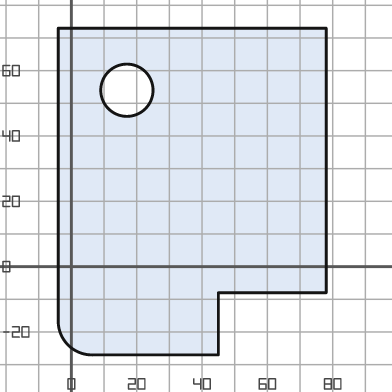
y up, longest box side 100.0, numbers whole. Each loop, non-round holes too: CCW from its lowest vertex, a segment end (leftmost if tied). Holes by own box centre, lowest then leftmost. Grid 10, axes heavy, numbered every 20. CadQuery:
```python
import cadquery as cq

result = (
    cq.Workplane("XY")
    .moveTo(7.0, -27.0)
    .lineTo(45.0, -27.0)
    .lineTo(45.0, -8.0)
    .lineTo(78.0, -8.0)
    .lineTo(78.0, 73.0)
    .lineTo(-4.0, 73.0)
    .lineTo(-4.0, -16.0)
    .threePointArc((-1.0, -24.0), (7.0, -27.0))
    .close()
    .moveTo(17.0, 54.0)
    .circle(8.0)
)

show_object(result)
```